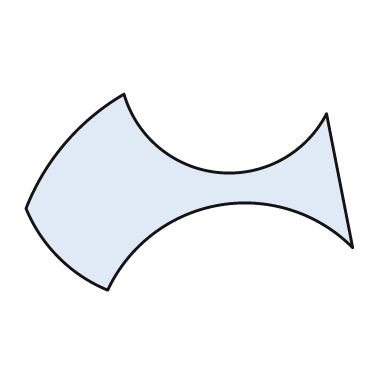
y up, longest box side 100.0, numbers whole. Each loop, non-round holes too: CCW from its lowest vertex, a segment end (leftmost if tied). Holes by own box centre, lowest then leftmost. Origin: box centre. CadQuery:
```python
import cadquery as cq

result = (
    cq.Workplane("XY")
    .moveTo(-25.0, -30.0)
    .threePointArc((9.0, -4.0), (50.0, -17.0))
    .lineTo(42.0, 24.0)
    .threePointArc((9.0, 6.0), (-20.0, 30.0))
    .threePointArc((-38.0, 15.0), (-50.0, -5.0))
    .threePointArc((-40.0, -20.0), (-25.0, -30.0))
    .close()
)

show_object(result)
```